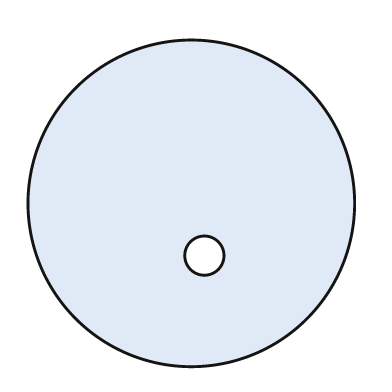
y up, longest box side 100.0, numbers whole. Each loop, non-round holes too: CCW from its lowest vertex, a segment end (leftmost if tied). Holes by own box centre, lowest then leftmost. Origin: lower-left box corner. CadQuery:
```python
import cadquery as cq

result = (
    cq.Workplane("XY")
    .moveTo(50.0, 50.0)
    .circle(50.0)
    .moveTo(54.0, 34.0)
    .circle(6.0)
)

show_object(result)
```